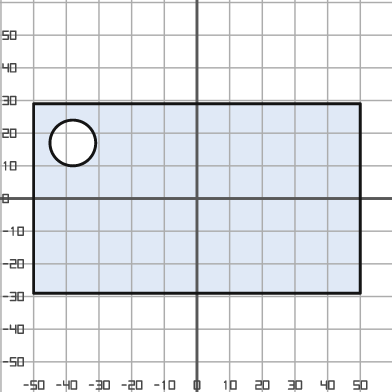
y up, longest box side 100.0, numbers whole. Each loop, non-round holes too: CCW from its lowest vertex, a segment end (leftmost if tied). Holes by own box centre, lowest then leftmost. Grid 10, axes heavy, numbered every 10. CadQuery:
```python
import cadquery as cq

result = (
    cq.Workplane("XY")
    .moveTo(-50.0, -29.0)
    .lineTo(50.0, -29.0)
    .lineTo(50.0, 29.0)
    .lineTo(-50.0, 29.0)
    .close()
    .moveTo(-38.0, 17.0)
    .circle(7.0)
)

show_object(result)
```